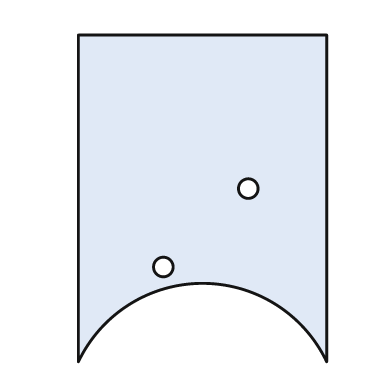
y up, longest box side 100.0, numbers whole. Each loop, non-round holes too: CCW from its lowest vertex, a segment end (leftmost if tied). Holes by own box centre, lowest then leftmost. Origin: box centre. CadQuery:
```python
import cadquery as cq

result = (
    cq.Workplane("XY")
    .moveTo(-38.0, -50.0)
    .threePointArc((0.0, -26.0), (38.0, -50.0))
    .lineTo(38.0, 50.0)
    .lineTo(-38.0, 50.0)
    .close()
    .moveTo(-12.0, -21.0)
    .circle(3.0)
    .moveTo(14.0, 3.0)
    .circle(3.0)
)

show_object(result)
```